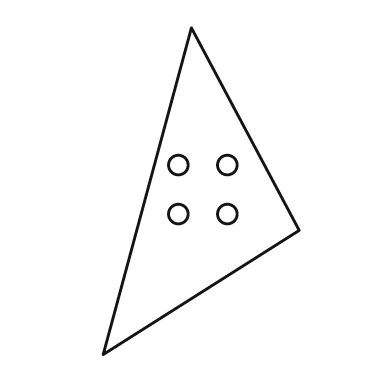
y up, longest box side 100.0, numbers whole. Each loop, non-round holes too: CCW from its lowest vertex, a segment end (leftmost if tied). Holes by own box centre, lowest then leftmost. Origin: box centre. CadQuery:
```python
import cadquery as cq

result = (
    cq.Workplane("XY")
    .moveTo(-30.0, -50.0)
    .lineTo(30.0, -12.0)
    .lineTo(-3.0, 50.0)
    .close()
    .moveTo(-7.0, -7.0)
    .circle(3.0)
    .moveTo(8.0, -7.0)
    .circle(3.0)
    .moveTo(-7.0, 8.0)
    .circle(3.0)
    .moveTo(8.0, 8.0)
    .circle(3.0)
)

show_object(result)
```